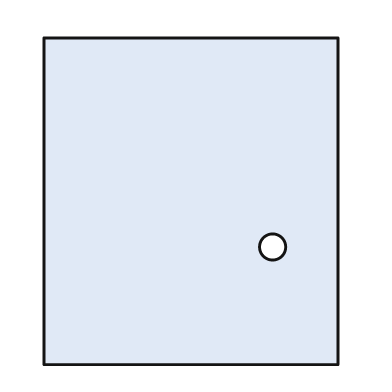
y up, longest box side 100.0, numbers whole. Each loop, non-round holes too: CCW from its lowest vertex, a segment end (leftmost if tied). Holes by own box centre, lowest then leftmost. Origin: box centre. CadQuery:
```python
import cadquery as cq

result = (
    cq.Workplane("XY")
    .moveTo(-45.0, -50.0)
    .lineTo(45.0, -50.0)
    .lineTo(45.0, 50.0)
    .lineTo(-45.0, 50.0)
    .close()
    .moveTo(25.0, -14.0)
    .circle(4.0)
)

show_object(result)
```